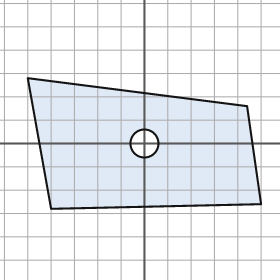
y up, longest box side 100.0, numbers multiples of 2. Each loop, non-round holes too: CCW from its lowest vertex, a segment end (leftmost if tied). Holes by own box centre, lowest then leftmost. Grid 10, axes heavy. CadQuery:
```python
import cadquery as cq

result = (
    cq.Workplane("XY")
    .moveTo(-40.0, -28.0)
    .lineTo(50.0, -26.0)
    .lineTo(44.0, 16.0)
    .lineTo(-50.0, 28.0)
    .close()
    .moveTo(0.0, 0.0)
    .circle(6.0)
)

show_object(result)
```